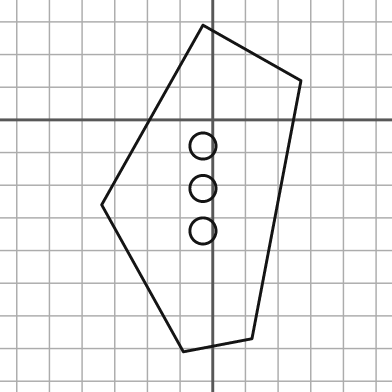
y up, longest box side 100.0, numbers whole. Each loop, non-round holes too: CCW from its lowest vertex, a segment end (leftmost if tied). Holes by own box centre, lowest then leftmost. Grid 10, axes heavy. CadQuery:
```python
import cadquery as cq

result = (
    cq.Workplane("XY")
    .moveTo(-9.0, -71.0)
    .lineTo(12.0, -67.0)
    .lineTo(27.0, 12.0)
    .lineTo(-3.0, 29.0)
    .lineTo(-34.0, -26.0)
    .close()
    .moveTo(-3.0, -34.0)
    .circle(4.0)
    .moveTo(-3.0, -21.0)
    .circle(4.0)
    .moveTo(-3.0, -8.0)
    .circle(4.0)
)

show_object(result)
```